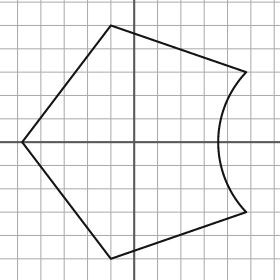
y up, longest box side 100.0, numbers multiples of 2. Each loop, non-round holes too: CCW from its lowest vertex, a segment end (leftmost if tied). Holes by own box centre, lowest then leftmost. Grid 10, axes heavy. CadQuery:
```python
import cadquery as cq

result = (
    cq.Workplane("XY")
    .moveTo(-10.0, -50.0)
    .lineTo(48.0, -30.0)
    .threePointArc((36.0, 0.0), (48.0, 30.0))
    .lineTo(-10.0, 50.0)
    .lineTo(-48.0, 0.0)
    .close()
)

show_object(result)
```